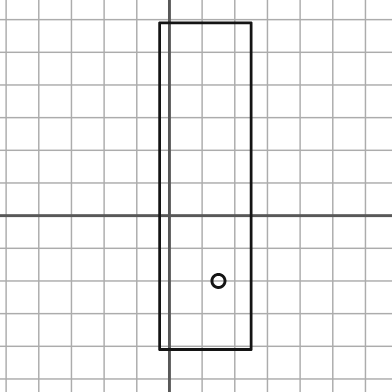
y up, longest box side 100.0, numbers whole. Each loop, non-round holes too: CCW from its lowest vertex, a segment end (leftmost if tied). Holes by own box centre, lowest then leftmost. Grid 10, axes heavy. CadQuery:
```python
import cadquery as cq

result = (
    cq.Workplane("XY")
    .moveTo(-3.0, -41.0)
    .lineTo(25.0, -41.0)
    .lineTo(25.0, 59.0)
    .lineTo(-3.0, 59.0)
    .close()
    .moveTo(15.0, -20.0)
    .circle(2.0)
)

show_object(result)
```